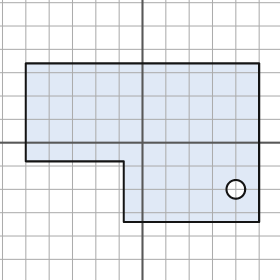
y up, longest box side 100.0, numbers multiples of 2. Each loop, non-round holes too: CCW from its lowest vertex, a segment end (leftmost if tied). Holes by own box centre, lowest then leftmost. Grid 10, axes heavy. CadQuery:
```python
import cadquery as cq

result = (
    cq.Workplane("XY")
    .moveTo(-8.0, -34.0)
    .lineTo(50.0, -34.0)
    .lineTo(50.0, 34.0)
    .lineTo(-50.0, 34.0)
    .lineTo(-50.0, -8.0)
    .lineTo(-8.0, -8.0)
    .close()
    .moveTo(40.0, -20.0)
    .circle(4.0)
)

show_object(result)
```